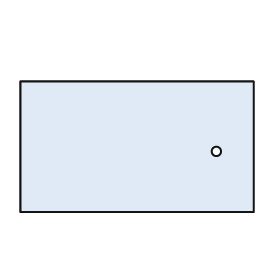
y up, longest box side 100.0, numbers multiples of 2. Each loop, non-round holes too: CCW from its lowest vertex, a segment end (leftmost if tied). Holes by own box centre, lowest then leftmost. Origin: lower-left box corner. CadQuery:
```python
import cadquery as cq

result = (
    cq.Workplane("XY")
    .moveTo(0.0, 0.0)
    .lineTo(100.0, 0.0)
    .lineTo(100.0, 56.0)
    .lineTo(0.0, 56.0)
    .close()
    .moveTo(84.0, 26.0)
    .circle(2.0)
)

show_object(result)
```